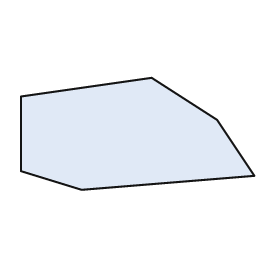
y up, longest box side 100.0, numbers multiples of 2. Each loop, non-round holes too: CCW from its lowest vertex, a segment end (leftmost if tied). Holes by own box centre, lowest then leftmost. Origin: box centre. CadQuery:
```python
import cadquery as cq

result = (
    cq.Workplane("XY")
    .moveTo(-24.0, -24.0)
    .lineTo(50.0, -18.0)
    .lineTo(34.0, 6.0)
    .lineTo(6.0, 24.0)
    .lineTo(-50.0, 16.0)
    .lineTo(-50.0, -16.0)
    .close()
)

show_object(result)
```